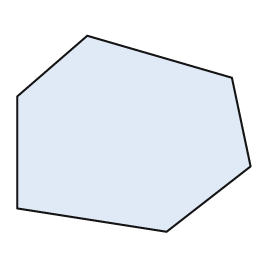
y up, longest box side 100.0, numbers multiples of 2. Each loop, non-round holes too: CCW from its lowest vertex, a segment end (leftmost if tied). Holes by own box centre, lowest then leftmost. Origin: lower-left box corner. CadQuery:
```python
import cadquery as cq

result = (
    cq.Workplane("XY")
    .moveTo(64.0, 0.0)
    .lineTo(100.0, 28.0)
    .lineTo(92.0, 66.0)
    .lineTo(30.0, 84.0)
    .lineTo(0.0, 58.0)
    .lineTo(0.0, 10.0)
    .close()
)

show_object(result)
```